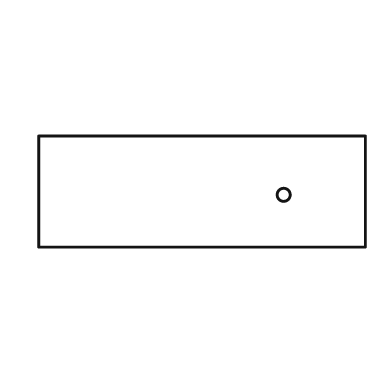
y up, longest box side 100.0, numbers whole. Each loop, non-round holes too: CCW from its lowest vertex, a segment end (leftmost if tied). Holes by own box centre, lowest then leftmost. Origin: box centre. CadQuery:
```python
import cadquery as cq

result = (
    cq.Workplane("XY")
    .moveTo(-50.0, -17.0)
    .lineTo(50.0, -17.0)
    .lineTo(50.0, 17.0)
    .lineTo(-50.0, 17.0)
    .close()
    .moveTo(25.0, -1.0)
    .circle(2.0)
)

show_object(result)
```